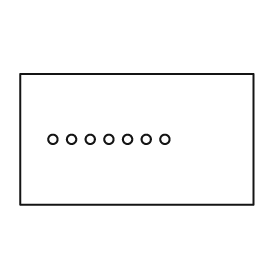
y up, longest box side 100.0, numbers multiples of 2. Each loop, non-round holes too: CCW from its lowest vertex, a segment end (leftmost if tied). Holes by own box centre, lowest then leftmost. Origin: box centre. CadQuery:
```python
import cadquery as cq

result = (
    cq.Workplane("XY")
    .moveTo(-50.0, -28.0)
    .lineTo(50.0, -28.0)
    .lineTo(50.0, 28.0)
    .lineTo(-50.0, 28.0)
    .close()
    .moveTo(-36.0, 0.0)
    .circle(2.0)
    .moveTo(-28.0, 0.0)
    .circle(2.0)
    .moveTo(-20.0, 0.0)
    .circle(2.0)
    .moveTo(-12.0, 0.0)
    .circle(2.0)
    .moveTo(-4.0, 0.0)
    .circle(2.0)
    .moveTo(4.0, 0.0)
    .circle(2.0)
    .moveTo(12.0, 0.0)
    .circle(2.0)
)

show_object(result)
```